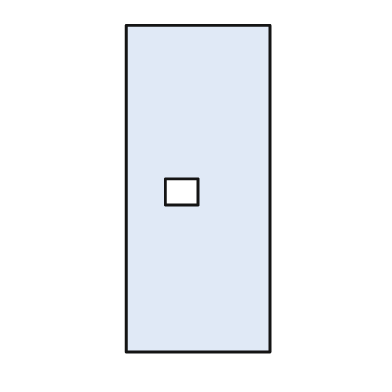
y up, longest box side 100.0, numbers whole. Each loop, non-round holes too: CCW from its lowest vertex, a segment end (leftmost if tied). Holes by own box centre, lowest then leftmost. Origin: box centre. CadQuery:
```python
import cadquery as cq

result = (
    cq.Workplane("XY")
    .moveTo(-22.0, -50.0)
    .lineTo(22.0, -50.0)
    .lineTo(22.0, 50.0)
    .lineTo(-22.0, 50.0)
    .close()
    .moveTo(-10.0, -5.0)
    .lineTo(0.0, -5.0)
    .lineTo(0.0, 3.0)
    .lineTo(-10.0, 3.0)
    .close()
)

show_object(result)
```